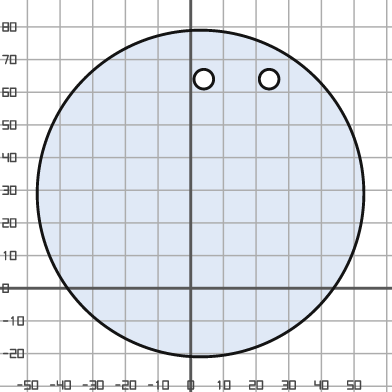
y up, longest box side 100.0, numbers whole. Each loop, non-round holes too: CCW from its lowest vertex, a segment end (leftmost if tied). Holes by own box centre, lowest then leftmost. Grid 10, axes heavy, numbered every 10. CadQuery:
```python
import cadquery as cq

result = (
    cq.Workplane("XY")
    .moveTo(3.0, 29.0)
    .circle(50.0)
    .moveTo(4.0, 64.0)
    .circle(3.0)
    .moveTo(24.0, 64.0)
    .circle(3.0)
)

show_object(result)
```